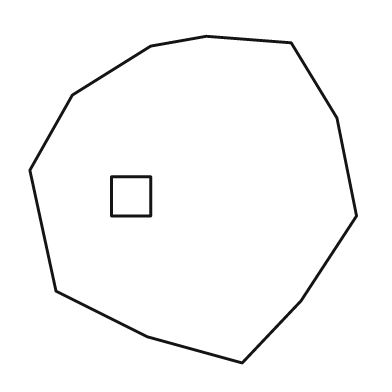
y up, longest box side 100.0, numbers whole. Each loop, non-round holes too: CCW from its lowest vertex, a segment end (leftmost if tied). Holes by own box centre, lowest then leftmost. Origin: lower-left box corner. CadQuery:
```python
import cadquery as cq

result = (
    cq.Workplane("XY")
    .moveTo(65.0, 0.0)
    .lineTo(83.0, 19.0)
    .lineTo(100.0, 45.0)
    .lineTo(94.0, 75.0)
    .lineTo(80.0, 98.0)
    .lineTo(54.0, 100.0)
    .lineTo(37.0, 97.0)
    .lineTo(13.0, 82.0)
    .lineTo(0.0, 59.0)
    .lineTo(8.0, 22.0)
    .lineTo(36.0, 8.0)
    .close()
    .moveTo(25.0, 45.0)
    .lineTo(37.0, 45.0)
    .lineTo(37.0, 57.0)
    .lineTo(25.0, 57.0)
    .close()
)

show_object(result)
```